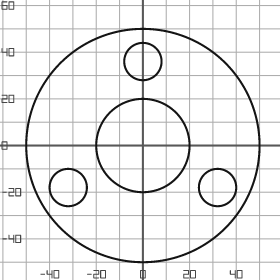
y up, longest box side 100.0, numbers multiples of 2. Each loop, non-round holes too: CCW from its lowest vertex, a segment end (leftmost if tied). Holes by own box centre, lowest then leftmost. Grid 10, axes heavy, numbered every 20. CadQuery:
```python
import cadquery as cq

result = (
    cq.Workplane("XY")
    .moveTo(0.0, 0.0)
    .circle(50.0)
    .moveTo(-32.0, -18.0)
    .circle(8.0)
    .moveTo(32.0, -18.0)
    .circle(8.0)
    .moveTo(0.0, 0.0)
    .circle(20.0)
    .moveTo(0.0, 36.0)
    .circle(8.0)
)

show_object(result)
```